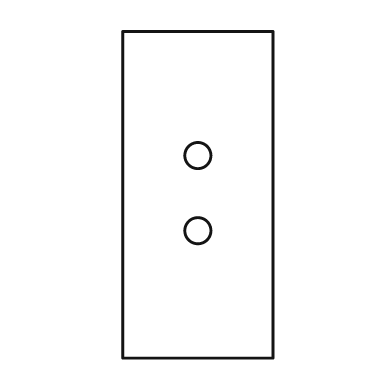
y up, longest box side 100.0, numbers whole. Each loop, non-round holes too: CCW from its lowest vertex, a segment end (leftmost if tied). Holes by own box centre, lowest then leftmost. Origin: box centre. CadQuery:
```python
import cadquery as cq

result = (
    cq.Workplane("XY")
    .moveTo(-23.0, -50.0)
    .lineTo(23.0, -50.0)
    .lineTo(23.0, 50.0)
    .lineTo(-23.0, 50.0)
    .close()
    .moveTo(0.0, -11.0)
    .circle(4.0)
    .moveTo(0.0, 12.0)
    .circle(4.0)
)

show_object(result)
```